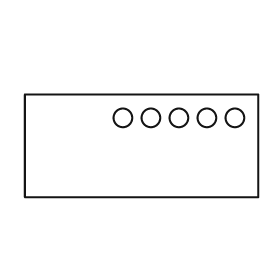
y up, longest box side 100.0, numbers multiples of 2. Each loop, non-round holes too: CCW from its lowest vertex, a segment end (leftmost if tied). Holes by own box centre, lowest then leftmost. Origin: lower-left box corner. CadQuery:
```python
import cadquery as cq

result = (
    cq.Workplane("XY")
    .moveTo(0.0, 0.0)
    .lineTo(100.0, 0.0)
    .lineTo(100.0, 44.0)
    .lineTo(0.0, 44.0)
    .close()
    .moveTo(42.0, 34.0)
    .circle(4.0)
    .moveTo(54.0, 34.0)
    .circle(4.0)
    .moveTo(66.0, 34.0)
    .circle(4.0)
    .moveTo(78.0, 34.0)
    .circle(4.0)
    .moveTo(90.0, 34.0)
    .circle(4.0)
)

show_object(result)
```